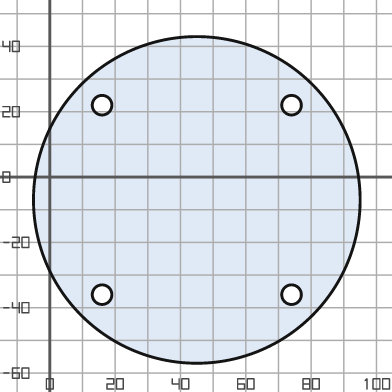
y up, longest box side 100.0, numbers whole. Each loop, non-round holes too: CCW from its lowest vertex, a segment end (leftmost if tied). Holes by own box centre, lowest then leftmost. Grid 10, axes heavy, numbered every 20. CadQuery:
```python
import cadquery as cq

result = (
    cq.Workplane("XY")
    .moveTo(45.0, -7.0)
    .circle(50.0)
    .moveTo(16.0, -36.0)
    .circle(3.0)
    .moveTo(74.0, -36.0)
    .circle(3.0)
    .moveTo(16.0, 22.0)
    .circle(3.0)
    .moveTo(74.0, 22.0)
    .circle(3.0)
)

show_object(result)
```